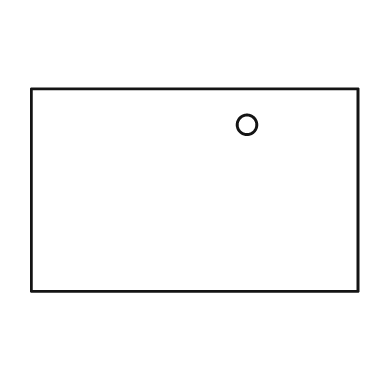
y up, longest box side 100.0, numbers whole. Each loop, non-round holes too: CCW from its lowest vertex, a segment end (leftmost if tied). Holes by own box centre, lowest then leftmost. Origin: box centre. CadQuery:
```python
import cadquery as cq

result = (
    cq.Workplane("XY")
    .moveTo(-50.0, -31.0)
    .lineTo(50.0, -31.0)
    .lineTo(50.0, 31.0)
    .lineTo(-50.0, 31.0)
    .close()
    .moveTo(16.0, 20.0)
    .circle(3.0)
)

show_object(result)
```